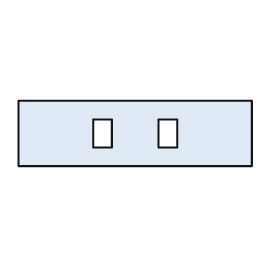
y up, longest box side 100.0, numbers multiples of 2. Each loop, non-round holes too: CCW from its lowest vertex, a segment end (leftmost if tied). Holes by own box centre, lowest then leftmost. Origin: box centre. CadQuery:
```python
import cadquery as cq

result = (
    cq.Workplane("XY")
    .moveTo(-50.0, -14.0)
    .lineTo(50.0, -14.0)
    .lineTo(50.0, 14.0)
    .lineTo(-50.0, 14.0)
    .close()
    .moveTo(-18.0, -6.0)
    .lineTo(-10.0, -6.0)
    .lineTo(-10.0, 6.0)
    .lineTo(-18.0, 6.0)
    .close()
    .moveTo(10.0, -6.0)
    .lineTo(18.0, -6.0)
    .lineTo(18.0, 6.0)
    .lineTo(10.0, 6.0)
    .close()
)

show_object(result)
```